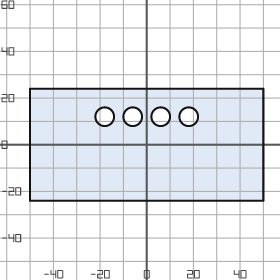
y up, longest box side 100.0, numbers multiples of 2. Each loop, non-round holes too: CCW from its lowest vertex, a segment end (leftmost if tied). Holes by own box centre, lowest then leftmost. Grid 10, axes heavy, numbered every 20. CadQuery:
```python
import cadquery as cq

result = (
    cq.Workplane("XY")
    .moveTo(-50.0, -24.0)
    .lineTo(50.0, -24.0)
    .lineTo(50.0, 24.0)
    .lineTo(-50.0, 24.0)
    .close()
    .moveTo(-18.0, 12.0)
    .circle(4.0)
    .moveTo(-6.0, 12.0)
    .circle(4.0)
    .moveTo(6.0, 12.0)
    .circle(4.0)
    .moveTo(18.0, 12.0)
    .circle(4.0)
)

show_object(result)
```